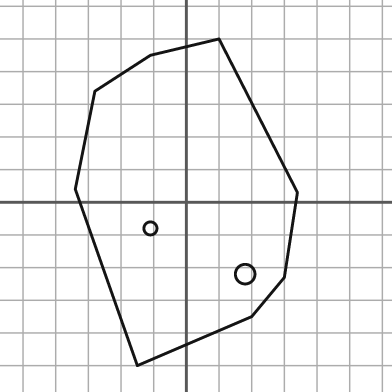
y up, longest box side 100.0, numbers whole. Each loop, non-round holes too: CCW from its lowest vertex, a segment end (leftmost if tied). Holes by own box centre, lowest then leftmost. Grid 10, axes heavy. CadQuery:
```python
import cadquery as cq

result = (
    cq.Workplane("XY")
    .moveTo(-15.0, -50.0)
    .lineTo(20.0, -35.0)
    .lineTo(30.0, -23.0)
    .lineTo(34.0, 3.0)
    .lineTo(10.0, 50.0)
    .lineTo(-11.0, 45.0)
    .lineTo(-28.0, 34.0)
    .lineTo(-34.0, 4.0)
    .close()
    .moveTo(18.0, -22.0)
    .circle(3.0)
    .moveTo(-11.0, -8.0)
    .circle(2.0)
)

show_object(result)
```